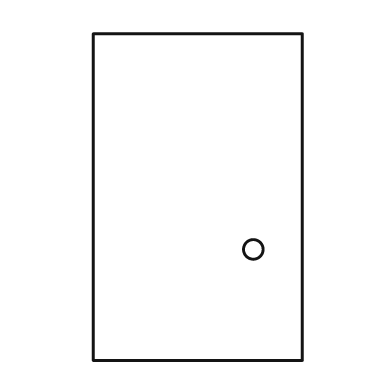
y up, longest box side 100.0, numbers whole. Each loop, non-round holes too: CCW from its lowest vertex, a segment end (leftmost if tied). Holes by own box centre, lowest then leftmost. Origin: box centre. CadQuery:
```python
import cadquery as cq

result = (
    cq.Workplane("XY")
    .moveTo(-32.0, -50.0)
    .lineTo(32.0, -50.0)
    .lineTo(32.0, 50.0)
    .lineTo(-32.0, 50.0)
    .close()
    .moveTo(17.0, -16.0)
    .circle(3.0)
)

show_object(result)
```